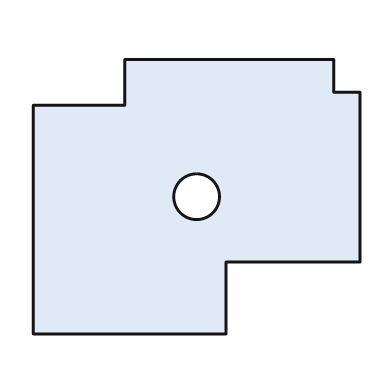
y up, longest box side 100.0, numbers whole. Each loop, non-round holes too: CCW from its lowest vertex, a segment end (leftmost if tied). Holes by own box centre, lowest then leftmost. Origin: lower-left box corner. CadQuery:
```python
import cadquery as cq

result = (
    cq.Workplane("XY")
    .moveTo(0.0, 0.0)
    .lineTo(59.0, 0.0)
    .lineTo(59.0, 22.0)
    .lineTo(100.0, 22.0)
    .lineTo(100.0, 74.0)
    .lineTo(92.0, 74.0)
    .lineTo(92.0, 84.0)
    .lineTo(28.0, 84.0)
    .lineTo(28.0, 70.0)
    .lineTo(0.0, 70.0)
    .close()
    .moveTo(50.0, 42.0)
    .circle(7.0)
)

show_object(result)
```